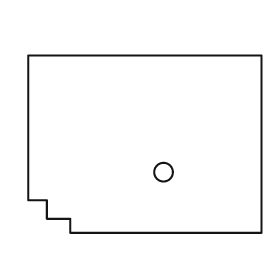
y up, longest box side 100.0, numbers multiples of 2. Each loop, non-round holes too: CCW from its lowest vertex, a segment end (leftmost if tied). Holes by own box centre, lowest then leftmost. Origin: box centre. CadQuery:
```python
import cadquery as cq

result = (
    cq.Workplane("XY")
    .moveTo(-32.0, -38.0)
    .lineTo(50.0, -38.0)
    .lineTo(50.0, 38.0)
    .lineTo(-50.0, 38.0)
    .lineTo(-50.0, -24.0)
    .lineTo(-42.0, -24.0)
    .lineTo(-42.0, -32.0)
    .lineTo(-32.0, -32.0)
    .close()
    .moveTo(8.0, -12.0)
    .circle(4.0)
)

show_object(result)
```